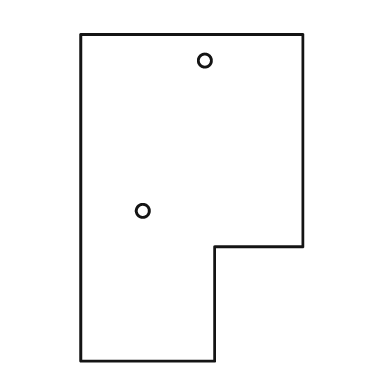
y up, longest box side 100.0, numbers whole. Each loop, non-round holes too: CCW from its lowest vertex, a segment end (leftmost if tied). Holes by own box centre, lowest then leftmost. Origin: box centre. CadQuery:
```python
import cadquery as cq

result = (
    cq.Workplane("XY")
    .moveTo(-34.0, -50.0)
    .lineTo(7.0, -50.0)
    .lineTo(7.0, -15.0)
    .lineTo(34.0, -15.0)
    .lineTo(34.0, 50.0)
    .lineTo(-34.0, 50.0)
    .close()
    .moveTo(-15.0, -4.0)
    .circle(2.0)
    .moveTo(4.0, 42.0)
    .circle(2.0)
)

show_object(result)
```